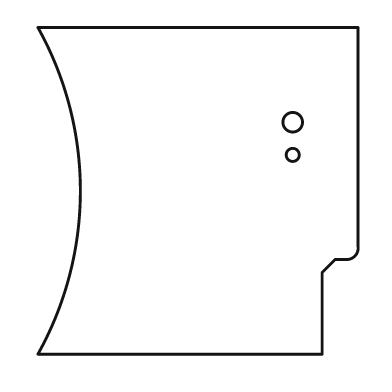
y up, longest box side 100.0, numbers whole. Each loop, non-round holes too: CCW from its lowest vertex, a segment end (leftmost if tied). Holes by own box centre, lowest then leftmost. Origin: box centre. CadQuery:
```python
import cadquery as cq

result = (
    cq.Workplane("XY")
    .moveTo(-49.0, -50.0)
    .lineTo(38.0, -50.0)
    .lineTo(38.0, -25.0)
    .lineTo(42.0, -21.0)
    .lineTo(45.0, -21.0)
    .threePointArc((48.0, -20.0), (49.0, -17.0))
    .lineTo(49.0, 50.0)
    .lineTo(-49.0, 50.0)
    .threePointArc((-36.0, 0.0), (-49.0, -50.0))
    .close()
    .moveTo(29.0, 11.0)
    .circle(2.0)
    .moveTo(29.0, 21.0)
    .circle(3.0)
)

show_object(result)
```